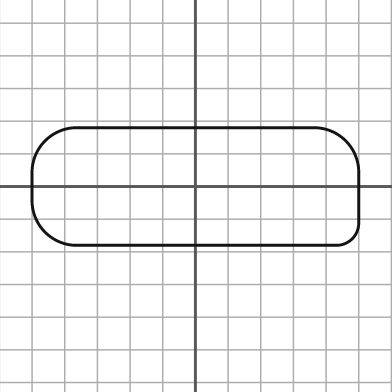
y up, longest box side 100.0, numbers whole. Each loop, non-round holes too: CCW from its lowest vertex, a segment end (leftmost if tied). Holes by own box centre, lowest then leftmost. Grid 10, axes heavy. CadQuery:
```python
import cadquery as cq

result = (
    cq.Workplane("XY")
    .moveTo(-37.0, -18.0)
    .lineTo(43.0, -18.0)
    .threePointArc((48.0, -16.0), (50.0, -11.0))
    .lineTo(50.0, 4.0)
    .threePointArc((46.0, 14.0), (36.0, 18.0))
    .lineTo(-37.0, 18.0)
    .threePointArc((-46.0, 14.0), (-50.0, 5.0))
    .lineTo(-50.0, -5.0)
    .threePointArc((-46.0, -14.0), (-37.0, -18.0))
    .close()
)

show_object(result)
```